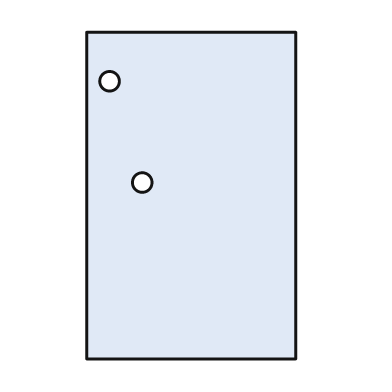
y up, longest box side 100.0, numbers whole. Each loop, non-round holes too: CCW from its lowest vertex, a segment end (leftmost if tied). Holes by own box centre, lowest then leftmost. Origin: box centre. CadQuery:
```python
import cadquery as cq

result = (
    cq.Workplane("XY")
    .moveTo(-32.0, -50.0)
    .lineTo(32.0, -50.0)
    .lineTo(32.0, 50.0)
    .lineTo(-32.0, 50.0)
    .close()
    .moveTo(-15.0, 4.0)
    .circle(3.0)
    .moveTo(-25.0, 35.0)
    .circle(3.0)
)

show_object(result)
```